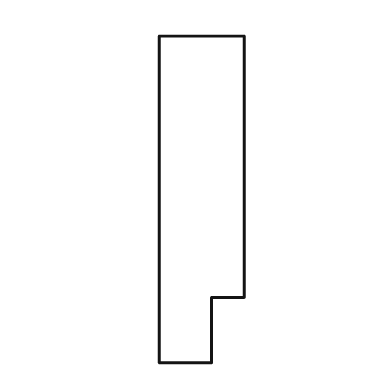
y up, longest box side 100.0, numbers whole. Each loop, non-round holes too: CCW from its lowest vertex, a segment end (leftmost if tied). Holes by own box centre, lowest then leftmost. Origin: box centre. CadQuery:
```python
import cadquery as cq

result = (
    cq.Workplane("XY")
    .moveTo(-13.0, -50.0)
    .lineTo(3.0, -50.0)
    .lineTo(3.0, -30.0)
    .lineTo(13.0, -30.0)
    .lineTo(13.0, 50.0)
    .lineTo(-13.0, 50.0)
    .close()
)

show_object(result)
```